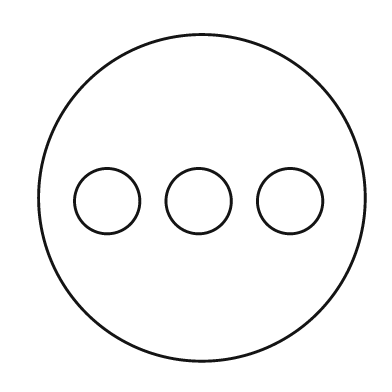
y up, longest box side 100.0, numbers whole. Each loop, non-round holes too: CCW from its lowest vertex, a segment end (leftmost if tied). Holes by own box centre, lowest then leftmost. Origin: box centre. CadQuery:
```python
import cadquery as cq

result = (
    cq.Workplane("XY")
    .moveTo(0.0, 0.0)
    .circle(50.0)
    .moveTo(-29.0, -1.0)
    .circle(10.0)
    .moveTo(-1.0, -1.0)
    .circle(10.0)
    .moveTo(27.0, -1.0)
    .circle(10.0)
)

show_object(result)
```